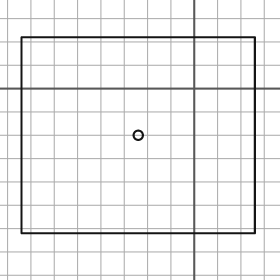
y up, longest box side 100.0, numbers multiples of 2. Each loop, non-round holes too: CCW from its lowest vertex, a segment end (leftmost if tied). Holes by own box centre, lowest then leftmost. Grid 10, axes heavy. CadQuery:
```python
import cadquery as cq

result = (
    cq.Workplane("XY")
    .moveTo(-74.0, -62.0)
    .lineTo(26.0, -62.0)
    .lineTo(26.0, 22.0)
    .lineTo(-74.0, 22.0)
    .close()
    .moveTo(-24.0, -20.0)
    .circle(2.0)
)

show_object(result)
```